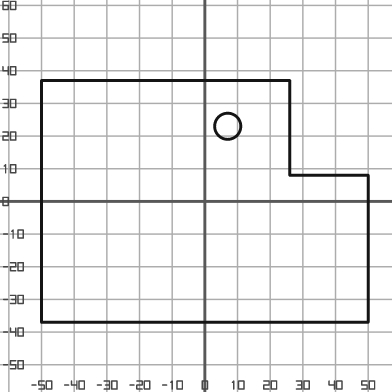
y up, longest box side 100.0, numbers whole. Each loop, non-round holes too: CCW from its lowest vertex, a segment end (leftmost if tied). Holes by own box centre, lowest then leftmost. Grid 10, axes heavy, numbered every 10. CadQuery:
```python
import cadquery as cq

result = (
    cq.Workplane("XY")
    .moveTo(-50.0, -37.0)
    .lineTo(50.0, -37.0)
    .lineTo(50.0, 8.0)
    .lineTo(26.0, 8.0)
    .lineTo(26.0, 37.0)
    .lineTo(-50.0, 37.0)
    .close()
    .moveTo(7.0, 23.0)
    .circle(4.0)
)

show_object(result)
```